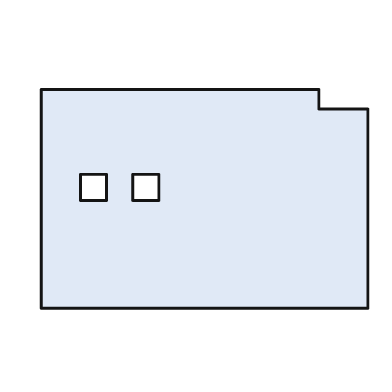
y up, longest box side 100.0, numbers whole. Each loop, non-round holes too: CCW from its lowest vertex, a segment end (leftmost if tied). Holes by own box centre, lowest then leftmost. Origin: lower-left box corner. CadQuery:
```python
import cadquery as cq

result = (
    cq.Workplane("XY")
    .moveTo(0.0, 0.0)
    .lineTo(100.0, 0.0)
    .lineTo(100.0, 61.0)
    .lineTo(85.0, 61.0)
    .lineTo(85.0, 67.0)
    .lineTo(0.0, 67.0)
    .close()
    .moveTo(12.0, 33.0)
    .lineTo(20.0, 33.0)
    .lineTo(20.0, 41.0)
    .lineTo(12.0, 41.0)
    .close()
    .moveTo(28.0, 33.0)
    .lineTo(36.0, 33.0)
    .lineTo(36.0, 41.0)
    .lineTo(28.0, 41.0)
    .close()
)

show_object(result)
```